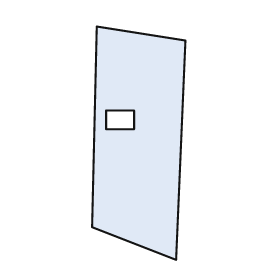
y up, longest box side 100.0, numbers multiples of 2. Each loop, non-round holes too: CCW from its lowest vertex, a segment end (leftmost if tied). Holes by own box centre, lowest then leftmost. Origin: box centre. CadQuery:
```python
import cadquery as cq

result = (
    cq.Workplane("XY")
    .moveTo(16.0, -50.0)
    .lineTo(20.0, 44.0)
    .lineTo(-18.0, 50.0)
    .lineTo(-20.0, -36.0)
    .close()
    .moveTo(-14.0, 6.0)
    .lineTo(-2.0, 6.0)
    .lineTo(-2.0, 14.0)
    .lineTo(-14.0, 14.0)
    .close()
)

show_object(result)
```